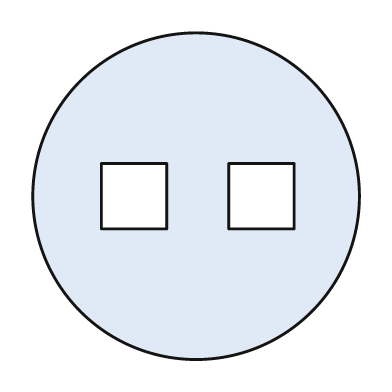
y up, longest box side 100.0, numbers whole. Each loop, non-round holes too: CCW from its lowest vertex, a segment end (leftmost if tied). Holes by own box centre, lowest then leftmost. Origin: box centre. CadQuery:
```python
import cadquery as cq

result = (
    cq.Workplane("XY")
    .moveTo(0.0, 0.0)
    .circle(50.0)
    .moveTo(-29.0, -10.0)
    .lineTo(-9.0, -10.0)
    .lineTo(-9.0, 10.0)
    .lineTo(-29.0, 10.0)
    .close()
    .moveTo(10.0, -10.0)
    .lineTo(30.0, -10.0)
    .lineTo(30.0, 10.0)
    .lineTo(10.0, 10.0)
    .close()
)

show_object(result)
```